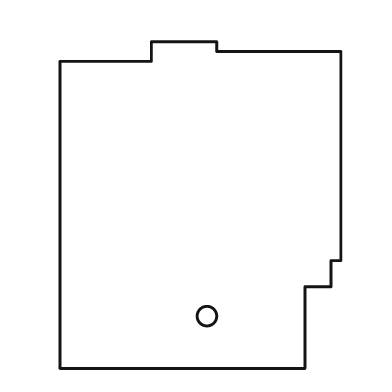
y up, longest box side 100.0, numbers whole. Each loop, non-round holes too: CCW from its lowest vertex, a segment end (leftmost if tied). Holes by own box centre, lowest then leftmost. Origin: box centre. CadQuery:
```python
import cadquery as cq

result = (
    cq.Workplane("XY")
    .moveTo(-43.0, -50.0)
    .lineTo(32.0, -50.0)
    .lineTo(32.0, -25.0)
    .lineTo(40.0, -25.0)
    .lineTo(40.0, -17.0)
    .lineTo(43.0, -17.0)
    .lineTo(43.0, 47.0)
    .lineTo(5.0, 47.0)
    .lineTo(5.0, 50.0)
    .lineTo(-15.0, 50.0)
    .lineTo(-15.0, 44.0)
    .lineTo(-43.0, 44.0)
    .close()
    .moveTo(2.0, -34.0)
    .circle(3.0)
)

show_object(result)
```